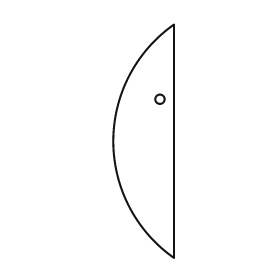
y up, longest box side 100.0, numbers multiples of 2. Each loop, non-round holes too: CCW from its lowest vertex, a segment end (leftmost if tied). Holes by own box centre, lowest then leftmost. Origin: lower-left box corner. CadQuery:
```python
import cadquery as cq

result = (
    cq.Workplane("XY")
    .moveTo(26.0, 0.0)
    .lineTo(26.0, 100.0)
    .threePointArc((0.0, 50.0), (26.0, 0.0))
    .close()
    .moveTo(20.0, 68.0)
    .circle(2.0)
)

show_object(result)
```